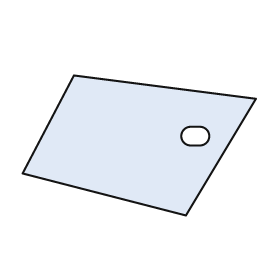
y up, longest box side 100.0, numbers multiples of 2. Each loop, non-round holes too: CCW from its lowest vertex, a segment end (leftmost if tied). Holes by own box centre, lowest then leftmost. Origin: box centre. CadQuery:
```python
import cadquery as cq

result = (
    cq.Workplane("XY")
    .moveTo(20.0, -30.0)
    .lineTo(50.0, 20.0)
    .lineTo(-28.0, 30.0)
    .lineTo(-50.0, -12.0)
    .close()
    .moveTo(22.0, 0.0)
    .lineTo(26.0, 0.0)
    .threePointArc((30.0, 4.0), (26.0, 8.0))
    .lineTo(22.0, 8.0)
    .threePointArc((18.0, 4.0), (22.0, 0.0))
    .close()
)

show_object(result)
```